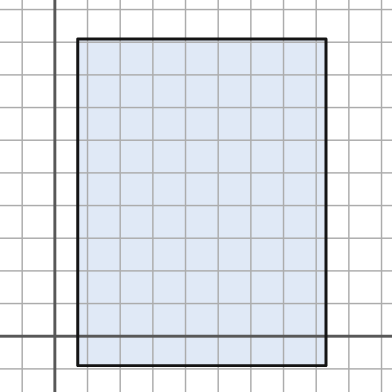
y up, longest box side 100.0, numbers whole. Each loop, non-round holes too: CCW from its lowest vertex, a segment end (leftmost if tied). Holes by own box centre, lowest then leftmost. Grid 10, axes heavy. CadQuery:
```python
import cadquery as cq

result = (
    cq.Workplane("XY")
    .moveTo(7.0, -9.0)
    .lineTo(83.0, -9.0)
    .lineTo(83.0, 91.0)
    .lineTo(7.0, 91.0)
    .close()
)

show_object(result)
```